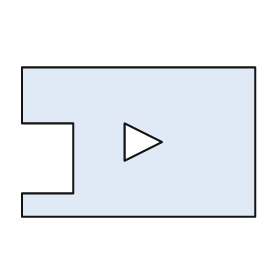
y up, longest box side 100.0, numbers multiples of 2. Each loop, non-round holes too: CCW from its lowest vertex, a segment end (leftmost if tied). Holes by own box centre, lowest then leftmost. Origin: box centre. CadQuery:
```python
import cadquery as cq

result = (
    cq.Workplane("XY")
    .moveTo(-50.0, -32.0)
    .lineTo(50.0, -32.0)
    .lineTo(50.0, 32.0)
    .lineTo(-50.0, 32.0)
    .lineTo(-50.0, 8.0)
    .lineTo(-28.0, 8.0)
    .lineTo(-28.0, -22.0)
    .lineTo(-50.0, -22.0)
    .close()
    .moveTo(-6.0, -8.0)
    .lineTo(10.0, 0.0)
    .lineTo(-6.0, 8.0)
    .close()
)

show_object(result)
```